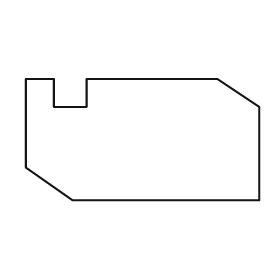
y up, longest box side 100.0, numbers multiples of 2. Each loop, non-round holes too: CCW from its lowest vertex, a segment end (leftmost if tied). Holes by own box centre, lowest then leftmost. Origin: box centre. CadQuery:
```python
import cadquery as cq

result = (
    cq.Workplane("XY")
    .moveTo(-30.0, -26.0)
    .lineTo(50.0, -26.0)
    .lineTo(50.0, 14.0)
    .lineTo(32.0, 26.0)
    .lineTo(-24.0, 26.0)
    .lineTo(-24.0, 14.0)
    .lineTo(-38.0, 14.0)
    .lineTo(-38.0, 26.0)
    .lineTo(-50.0, 26.0)
    .lineTo(-50.0, -12.0)
    .close()
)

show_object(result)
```